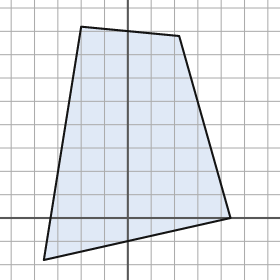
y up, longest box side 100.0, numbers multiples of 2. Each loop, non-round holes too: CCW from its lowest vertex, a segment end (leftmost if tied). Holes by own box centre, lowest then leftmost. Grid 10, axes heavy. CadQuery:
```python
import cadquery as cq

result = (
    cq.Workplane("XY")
    .moveTo(-36.0, -18.0)
    .lineTo(44.0, 0.0)
    .lineTo(22.0, 78.0)
    .lineTo(-20.0, 82.0)
    .close()
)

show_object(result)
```